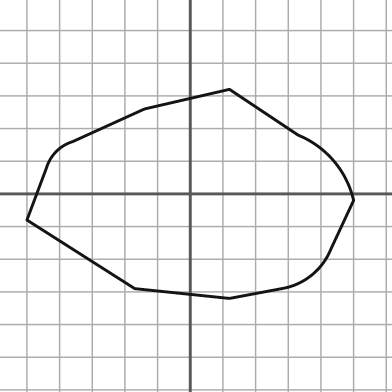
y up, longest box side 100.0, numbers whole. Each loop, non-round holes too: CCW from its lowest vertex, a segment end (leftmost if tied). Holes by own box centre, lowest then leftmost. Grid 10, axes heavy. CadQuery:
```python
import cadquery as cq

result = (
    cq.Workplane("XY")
    .moveTo(12.0, -32.0)
    .lineTo(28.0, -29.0)
    .threePointArc((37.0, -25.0), (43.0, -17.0))
    .lineTo(50.0, -2.0)
    .threePointArc((44.0, 10.0), (33.0, 18.0))
    .lineTo(12.0, 32.0)
    .lineTo(-14.0, 26.0)
    .lineTo(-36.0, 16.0)
    .threePointArc((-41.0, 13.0), (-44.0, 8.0))
    .lineTo(-50.0, -8.0)
    .lineTo(-17.0, -29.0)
    .close()
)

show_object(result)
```